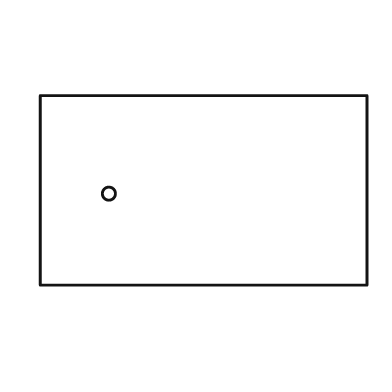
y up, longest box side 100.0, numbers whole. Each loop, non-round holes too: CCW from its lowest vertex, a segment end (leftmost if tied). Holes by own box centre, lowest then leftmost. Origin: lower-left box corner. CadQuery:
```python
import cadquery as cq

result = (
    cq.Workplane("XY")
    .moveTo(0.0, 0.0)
    .lineTo(100.0, 0.0)
    .lineTo(100.0, 58.0)
    .lineTo(0.0, 58.0)
    .close()
    .moveTo(21.0, 28.0)
    .circle(2.0)
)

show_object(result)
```